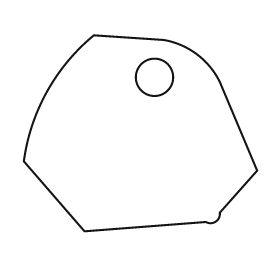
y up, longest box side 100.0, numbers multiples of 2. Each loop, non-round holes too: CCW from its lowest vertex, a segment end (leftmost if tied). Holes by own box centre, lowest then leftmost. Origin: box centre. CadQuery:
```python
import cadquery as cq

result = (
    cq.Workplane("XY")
    .moveTo(-24.0, -42.0)
    .lineTo(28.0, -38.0)
    .threePointArc((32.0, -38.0), (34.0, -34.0))
    .lineTo(50.0, -16.0)
    .lineTo(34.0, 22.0)
    .threePointArc((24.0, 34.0), (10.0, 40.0))
    .lineTo(-20.0, 42.0)
    .threePointArc((-40.0, 18.0), (-50.0, -12.0))
    .close()
    .moveTo(6.0, 24.0)
    .circle(8.0)
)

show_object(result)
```